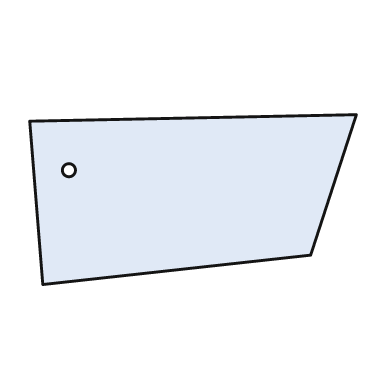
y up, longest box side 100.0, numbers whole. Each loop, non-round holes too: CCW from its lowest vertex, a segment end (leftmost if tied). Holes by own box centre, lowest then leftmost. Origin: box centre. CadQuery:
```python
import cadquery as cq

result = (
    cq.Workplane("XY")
    .moveTo(-46.0, -26.0)
    .lineTo(36.0, -17.0)
    .lineTo(50.0, 26.0)
    .lineTo(-50.0, 24.0)
    .close()
    .moveTo(-38.0, 9.0)
    .circle(2.0)
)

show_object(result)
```